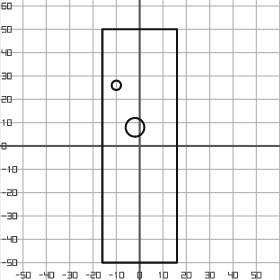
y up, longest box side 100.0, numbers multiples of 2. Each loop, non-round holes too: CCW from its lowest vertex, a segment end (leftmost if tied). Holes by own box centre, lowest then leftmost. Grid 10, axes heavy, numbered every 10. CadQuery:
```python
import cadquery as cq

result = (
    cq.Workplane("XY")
    .moveTo(-16.0, -50.0)
    .lineTo(16.0, -50.0)
    .lineTo(16.0, 50.0)
    .lineTo(-16.0, 50.0)
    .close()
    .moveTo(-2.0, 8.0)
    .circle(4.0)
    .moveTo(-10.0, 26.0)
    .circle(2.0)
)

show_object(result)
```